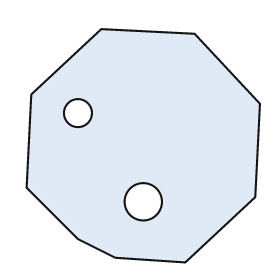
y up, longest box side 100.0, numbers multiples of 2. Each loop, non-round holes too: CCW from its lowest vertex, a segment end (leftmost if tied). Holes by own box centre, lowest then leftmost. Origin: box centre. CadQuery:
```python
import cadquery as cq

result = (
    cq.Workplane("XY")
    .moveTo(18.0, -50.0)
    .lineTo(48.0, -22.0)
    .lineTo(50.0, 18.0)
    .lineTo(22.0, 48.0)
    .lineTo(-18.0, 50.0)
    .lineTo(-48.0, 22.0)
    .lineTo(-50.0, -18.0)
    .lineTo(-28.0, -40.0)
    .lineTo(-12.0, -48.0)
    .close()
    .moveTo(0.0, -24.0)
    .circle(8.0)
    .moveTo(-28.0, 14.0)
    .circle(6.0)
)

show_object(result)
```